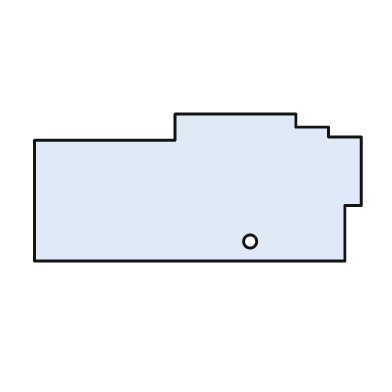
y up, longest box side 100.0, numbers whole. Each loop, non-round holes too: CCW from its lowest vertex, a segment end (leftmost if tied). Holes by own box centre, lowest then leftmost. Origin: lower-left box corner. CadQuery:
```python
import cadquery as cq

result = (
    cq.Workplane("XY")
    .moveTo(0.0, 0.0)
    .lineTo(95.0, 0.0)
    .lineTo(95.0, 17.0)
    .lineTo(100.0, 17.0)
    .lineTo(100.0, 38.0)
    .lineTo(90.0, 38.0)
    .lineTo(90.0, 41.0)
    .lineTo(80.0, 41.0)
    .lineTo(80.0, 45.0)
    .lineTo(43.0, 45.0)
    .lineTo(43.0, 37.0)
    .lineTo(0.0, 37.0)
    .close()
    .moveTo(66.0, 6.0)
    .circle(2.0)
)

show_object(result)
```